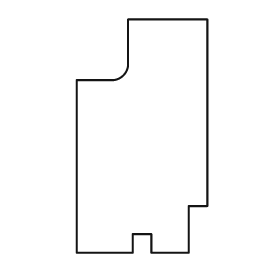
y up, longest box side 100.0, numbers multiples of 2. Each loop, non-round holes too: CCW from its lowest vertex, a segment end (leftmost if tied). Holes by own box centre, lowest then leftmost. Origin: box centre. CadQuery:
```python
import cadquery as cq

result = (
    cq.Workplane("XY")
    .moveTo(-28.0, -50.0)
    .lineTo(-4.0, -50.0)
    .lineTo(-4.0, -42.0)
    .lineTo(4.0, -42.0)
    .lineTo(4.0, -50.0)
    .lineTo(20.0, -50.0)
    .lineTo(20.0, -30.0)
    .lineTo(28.0, -30.0)
    .lineTo(28.0, 50.0)
    .lineTo(-6.0, 50.0)
    .lineTo(-6.0, 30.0)
    .threePointArc((-8.0, 26.0), (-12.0, 24.0))
    .lineTo(-28.0, 24.0)
    .close()
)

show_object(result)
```